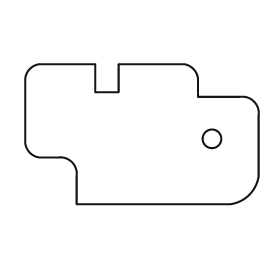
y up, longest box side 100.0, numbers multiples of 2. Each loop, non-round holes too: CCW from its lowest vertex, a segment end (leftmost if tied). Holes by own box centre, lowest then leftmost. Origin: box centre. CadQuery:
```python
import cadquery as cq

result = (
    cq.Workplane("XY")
    .moveTo(-28.0, -30.0)
    .lineTo(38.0, -30.0)
    .threePointArc((46.0, -26.0), (50.0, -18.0))
    .lineTo(50.0, 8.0)
    .threePointArc((48.0, 14.0), (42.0, 16.0))
    .lineTo(24.0, 16.0)
    .lineTo(24.0, 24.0)
    .threePointArc((22.0, 28.0), (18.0, 30.0))
    .lineTo(-10.0, 30.0)
    .lineTo(-10.0, 18.0)
    .lineTo(-20.0, 18.0)
    .lineTo(-20.0, 30.0)
    .lineTo(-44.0, 30.0)
    .threePointArc((-48.0, 28.0), (-50.0, 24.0))
    .lineTo(-50.0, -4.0)
    .threePointArc((-48.0, -8.0), (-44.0, -10.0))
    .lineTo(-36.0, -10.0)
    .threePointArc((-30.0, -12.0), (-28.0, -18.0))
    .close()
    .moveTo(30.0, -2.0)
    .circle(4.0)
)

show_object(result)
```